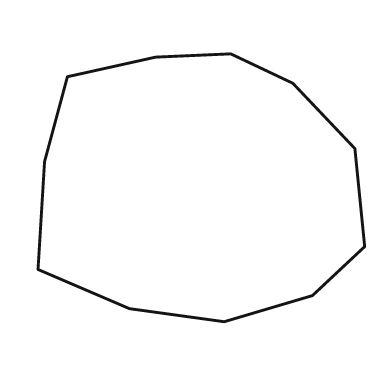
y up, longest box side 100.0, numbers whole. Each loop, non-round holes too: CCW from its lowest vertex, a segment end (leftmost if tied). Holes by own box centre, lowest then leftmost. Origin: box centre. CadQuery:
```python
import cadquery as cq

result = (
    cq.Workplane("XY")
    .moveTo(7.0, -41.0)
    .lineTo(34.0, -33.0)
    .lineTo(50.0, -18.0)
    .lineTo(47.0, 12.0)
    .lineTo(28.0, 32.0)
    .lineTo(9.0, 41.0)
    .lineTo(-14.0, 40.0)
    .lineTo(-41.0, 34.0)
    .lineTo(-48.0, 8.0)
    .lineTo(-50.0, -25.0)
    .lineTo(-22.0, -37.0)
    .close()
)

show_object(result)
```